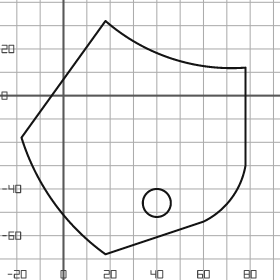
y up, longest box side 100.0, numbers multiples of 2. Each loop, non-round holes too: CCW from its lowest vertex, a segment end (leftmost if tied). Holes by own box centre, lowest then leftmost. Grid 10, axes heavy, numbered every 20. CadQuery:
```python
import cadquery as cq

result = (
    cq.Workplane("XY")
    .moveTo(18.0, -68.0)
    .lineTo(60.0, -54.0)
    .threePointArc((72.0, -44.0), (78.0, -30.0))
    .lineTo(78.0, 12.0)
    .threePointArc((46.0, 16.0), (18.0, 32.0))
    .lineTo(-18.0, -18.0)
    .threePointArc((-4.0, -46.0), (18.0, -68.0))
    .close()
    .moveTo(40.0, -46.0)
    .circle(6.0)
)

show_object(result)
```